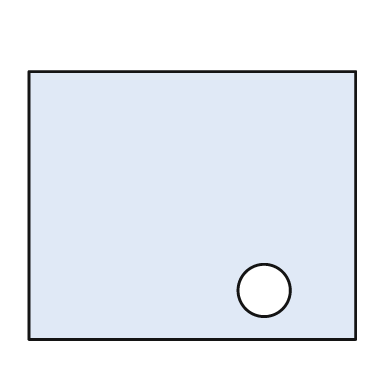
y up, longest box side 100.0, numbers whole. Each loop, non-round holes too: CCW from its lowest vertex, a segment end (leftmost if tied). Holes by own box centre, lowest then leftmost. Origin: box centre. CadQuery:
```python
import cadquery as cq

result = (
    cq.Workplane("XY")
    .moveTo(-50.0, -41.0)
    .lineTo(50.0, -41.0)
    .lineTo(50.0, 41.0)
    .lineTo(-50.0, 41.0)
    .close()
    .moveTo(22.0, -26.0)
    .circle(8.0)
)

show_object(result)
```